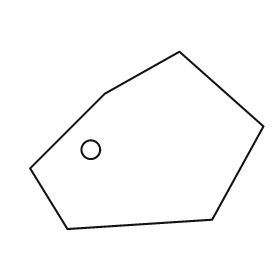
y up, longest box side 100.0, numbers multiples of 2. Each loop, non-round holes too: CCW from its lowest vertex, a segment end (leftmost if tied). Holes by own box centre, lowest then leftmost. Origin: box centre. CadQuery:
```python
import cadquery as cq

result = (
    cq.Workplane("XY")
    .moveTo(-34.0, -38.0)
    .lineTo(28.0, -34.0)
    .lineTo(50.0, 6.0)
    .lineTo(14.0, 38.0)
    .lineTo(-18.0, 20.0)
    .lineTo(-50.0, -12.0)
    .close()
    .moveTo(-24.0, -4.0)
    .circle(4.0)
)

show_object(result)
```